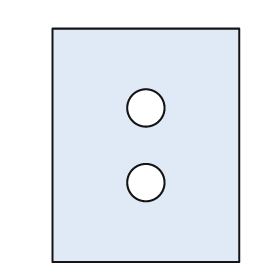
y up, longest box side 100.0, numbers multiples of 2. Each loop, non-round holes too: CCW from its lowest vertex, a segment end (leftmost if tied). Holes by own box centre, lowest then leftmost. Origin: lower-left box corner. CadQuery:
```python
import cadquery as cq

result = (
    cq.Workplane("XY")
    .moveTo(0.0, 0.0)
    .lineTo(80.0, 0.0)
    .lineTo(80.0, 100.0)
    .lineTo(0.0, 100.0)
    .close()
    .moveTo(40.0, 34.0)
    .circle(8.0)
    .moveTo(40.0, 66.0)
    .circle(8.0)
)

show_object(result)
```